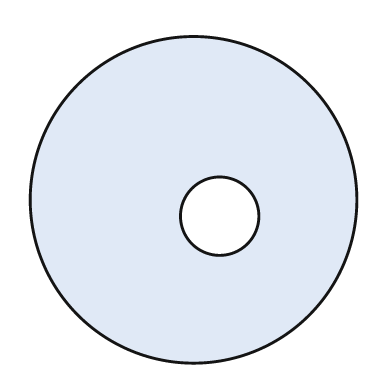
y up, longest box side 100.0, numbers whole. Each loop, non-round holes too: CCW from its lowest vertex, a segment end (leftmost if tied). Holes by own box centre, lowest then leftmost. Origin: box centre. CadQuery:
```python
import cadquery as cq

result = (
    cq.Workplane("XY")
    .moveTo(0.0, 0.0)
    .circle(50.0)
    .moveTo(8.0, -5.0)
    .circle(12.0)
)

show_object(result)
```